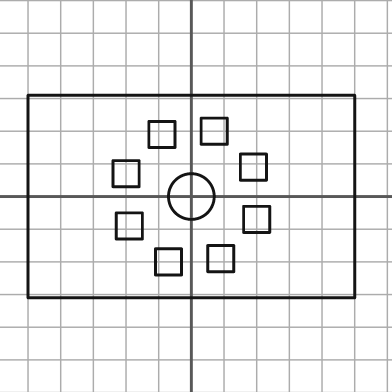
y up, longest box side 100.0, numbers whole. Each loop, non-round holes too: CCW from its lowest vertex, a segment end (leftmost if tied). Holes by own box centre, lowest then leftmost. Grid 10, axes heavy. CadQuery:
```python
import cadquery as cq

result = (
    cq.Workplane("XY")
    .moveTo(-50.0, -31.0)
    .lineTo(50.0, -31.0)
    .lineTo(50.0, 31.0)
    .lineTo(-50.0, 31.0)
    .close()
    .moveTo(-11.0, -24.0)
    .lineTo(-3.0, -24.0)
    .lineTo(-3.0, -16.0)
    .lineTo(-11.0, -16.0)
    .close()
    .moveTo(5.0, -23.0)
    .lineTo(13.0, -23.0)
    .lineTo(13.0, -15.0)
    .lineTo(5.0, -15.0)
    .close()
    .moveTo(-23.0, -13.0)
    .lineTo(-15.0, -13.0)
    .lineTo(-15.0, -5.0)
    .lineTo(-23.0, -5.0)
    .close()
    .moveTo(16.0, -11.0)
    .lineTo(24.0, -11.0)
    .lineTo(24.0, -3.0)
    .lineTo(16.0, -3.0)
    .close()
    .moveTo(0.0, 0.0)
    .circle(7.0)
    .moveTo(-24.0, 3.0)
    .lineTo(-16.0, 3.0)
    .lineTo(-16.0, 11.0)
    .lineTo(-24.0, 11.0)
    .close()
    .moveTo(15.0, 5.0)
    .lineTo(23.0, 5.0)
    .lineTo(23.0, 13.0)
    .lineTo(15.0, 13.0)
    .close()
    .moveTo(-13.0, 15.0)
    .lineTo(-5.0, 15.0)
    .lineTo(-5.0, 23.0)
    .lineTo(-13.0, 23.0)
    .close()
    .moveTo(3.0, 16.0)
    .lineTo(11.0, 16.0)
    .lineTo(11.0, 24.0)
    .lineTo(3.0, 24.0)
    .close()
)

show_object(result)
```